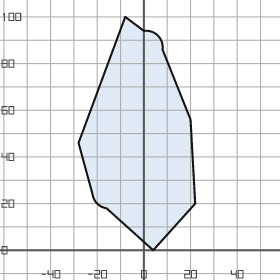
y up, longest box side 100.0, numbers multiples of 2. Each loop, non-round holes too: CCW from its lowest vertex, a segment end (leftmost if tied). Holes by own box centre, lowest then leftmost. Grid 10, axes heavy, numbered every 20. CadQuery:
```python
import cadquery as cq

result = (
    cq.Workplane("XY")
    .moveTo(4.0, 0.0)
    .lineTo(22.0, 20.0)
    .lineTo(20.0, 56.0)
    .lineTo(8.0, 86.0)
    .threePointArc((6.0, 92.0), (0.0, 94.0))
    .lineTo(-8.0, 100.0)
    .lineTo(-28.0, 46.0)
    .lineTo(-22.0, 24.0)
    .threePointArc((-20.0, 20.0), (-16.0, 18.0))
    .close()
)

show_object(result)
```